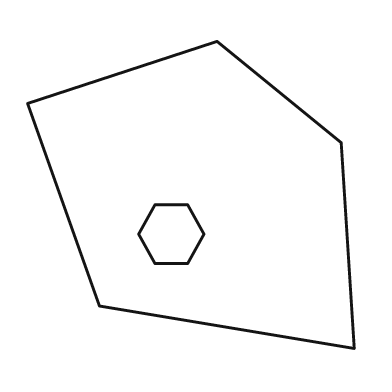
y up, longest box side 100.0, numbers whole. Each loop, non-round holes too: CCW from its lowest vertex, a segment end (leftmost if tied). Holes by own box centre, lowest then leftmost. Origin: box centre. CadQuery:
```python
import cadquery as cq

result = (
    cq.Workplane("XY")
    .moveTo(50.0, -47.0)
    .lineTo(46.0, 16.0)
    .lineTo(8.0, 47.0)
    .lineTo(-50.0, 28.0)
    .lineTo(-28.0, -34.0)
    .close()
    .moveTo(-11.0, -21.0)
    .lineTo(-1.0, -21.0)
    .lineTo(4.0, -12.0)
    .lineTo(-1.0, -3.0)
    .lineTo(-11.0, -3.0)
    .lineTo(-16.0, -12.0)
    .close()
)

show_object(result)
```